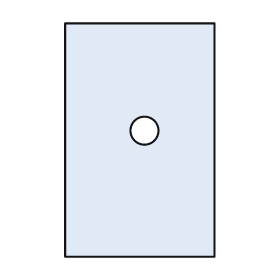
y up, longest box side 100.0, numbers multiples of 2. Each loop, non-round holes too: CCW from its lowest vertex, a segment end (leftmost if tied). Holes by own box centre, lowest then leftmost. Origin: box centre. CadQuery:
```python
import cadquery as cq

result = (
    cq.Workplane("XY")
    .moveTo(-32.0, -50.0)
    .lineTo(32.0, -50.0)
    .lineTo(32.0, 50.0)
    .lineTo(-32.0, 50.0)
    .close()
    .moveTo(2.0, 4.0)
    .circle(6.0)
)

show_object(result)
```